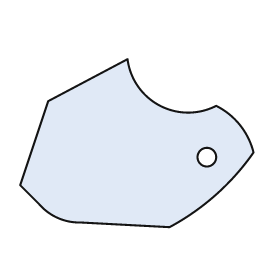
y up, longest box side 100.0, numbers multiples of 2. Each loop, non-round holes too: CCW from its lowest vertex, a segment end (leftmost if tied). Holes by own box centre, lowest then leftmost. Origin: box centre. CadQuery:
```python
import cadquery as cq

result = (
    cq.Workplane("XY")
    .moveTo(14.0, -36.0)
    .threePointArc((34.0, -22.0), (50.0, -4.0))
    .threePointArc((44.0, 8.0), (34.0, 16.0))
    .threePointArc((10.0, 16.0), (-4.0, 36.0))
    .lineTo(-38.0, 18.0)
    .lineTo(-50.0, -18.0)
    .lineTo(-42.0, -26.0)
    .threePointArc((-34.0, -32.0), (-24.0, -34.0))
    .close()
    .moveTo(30.0, -6.0)
    .circle(4.0)
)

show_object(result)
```